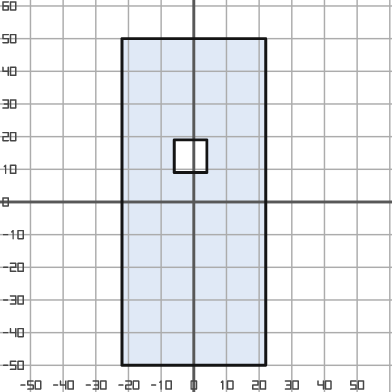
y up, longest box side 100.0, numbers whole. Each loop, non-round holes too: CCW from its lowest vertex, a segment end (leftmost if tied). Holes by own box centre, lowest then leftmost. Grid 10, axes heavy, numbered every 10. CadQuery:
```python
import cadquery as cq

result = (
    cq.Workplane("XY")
    .moveTo(-22.0, -50.0)
    .lineTo(22.0, -50.0)
    .lineTo(22.0, 50.0)
    .lineTo(-22.0, 50.0)
    .close()
    .moveTo(-6.0, 9.0)
    .lineTo(4.0, 9.0)
    .lineTo(4.0, 19.0)
    .lineTo(-6.0, 19.0)
    .close()
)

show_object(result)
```